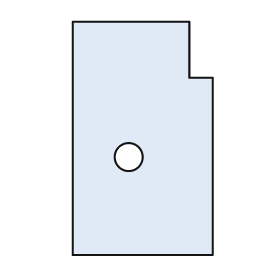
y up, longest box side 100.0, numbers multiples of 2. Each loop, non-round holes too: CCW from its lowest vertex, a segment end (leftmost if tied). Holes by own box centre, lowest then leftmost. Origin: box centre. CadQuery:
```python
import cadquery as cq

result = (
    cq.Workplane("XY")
    .moveTo(-30.0, -50.0)
    .lineTo(30.0, -50.0)
    .lineTo(30.0, 26.0)
    .lineTo(20.0, 26.0)
    .lineTo(20.0, 50.0)
    .lineTo(-30.0, 50.0)
    .close()
    .moveTo(-6.0, -8.0)
    .circle(6.0)
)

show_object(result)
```